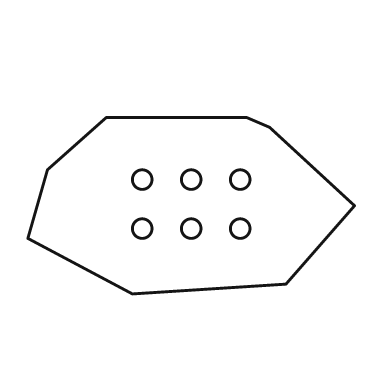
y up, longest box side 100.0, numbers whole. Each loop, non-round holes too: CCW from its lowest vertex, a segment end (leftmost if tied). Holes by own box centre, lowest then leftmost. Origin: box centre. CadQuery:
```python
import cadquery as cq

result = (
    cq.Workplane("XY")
    .moveTo(-18.0, -27.0)
    .lineTo(29.0, -24.0)
    .lineTo(50.0, 0.0)
    .lineTo(24.0, 24.0)
    .lineTo(17.0, 27.0)
    .lineTo(-26.0, 27.0)
    .lineTo(-44.0, 11.0)
    .lineTo(-50.0, -10.0)
    .close()
    .moveTo(-15.0, -7.0)
    .circle(3.0)
    .moveTo(0.0, -7.0)
    .circle(3.0)
    .moveTo(15.0, -7.0)
    .circle(3.0)
    .moveTo(-15.0, 8.0)
    .circle(3.0)
    .moveTo(0.0, 8.0)
    .circle(3.0)
    .moveTo(15.0, 8.0)
    .circle(3.0)
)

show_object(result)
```